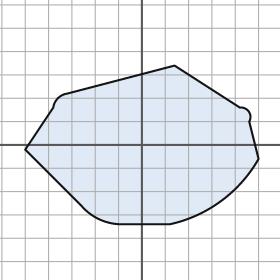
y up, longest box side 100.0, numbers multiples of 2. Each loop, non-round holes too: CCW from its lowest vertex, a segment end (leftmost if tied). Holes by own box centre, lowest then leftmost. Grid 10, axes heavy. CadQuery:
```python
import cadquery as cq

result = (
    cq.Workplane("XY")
    .moveTo(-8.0, -34.0)
    .lineTo(12.0, -34.0)
    .threePointArc((34.0, -24.0), (50.0, -6.0))
    .lineTo(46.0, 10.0)
    .threePointArc((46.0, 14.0), (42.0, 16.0))
    .lineTo(14.0, 34.0)
    .lineTo(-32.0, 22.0)
    .threePointArc((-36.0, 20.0), (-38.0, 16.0))
    .lineTo(-50.0, -2.0)
    .lineTo(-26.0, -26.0)
    .threePointArc((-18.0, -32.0), (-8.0, -34.0))
    .close()
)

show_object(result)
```